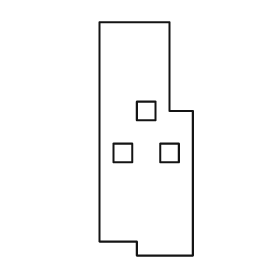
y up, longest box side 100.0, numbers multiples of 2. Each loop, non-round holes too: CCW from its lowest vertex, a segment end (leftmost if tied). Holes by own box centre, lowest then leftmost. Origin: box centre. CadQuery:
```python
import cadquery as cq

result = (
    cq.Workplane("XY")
    .moveTo(-4.0, -50.0)
    .lineTo(20.0, -50.0)
    .lineTo(20.0, 12.0)
    .lineTo(10.0, 12.0)
    .lineTo(10.0, 50.0)
    .lineTo(-20.0, 50.0)
    .lineTo(-20.0, -44.0)
    .lineTo(-4.0, -44.0)
    .close()
    .moveTo(-14.0, -10.0)
    .lineTo(-6.0, -10.0)
    .lineTo(-6.0, -2.0)
    .lineTo(-14.0, -2.0)
    .close()
    .moveTo(6.0, -10.0)
    .lineTo(14.0, -10.0)
    .lineTo(14.0, -2.0)
    .lineTo(6.0, -2.0)
    .close()
    .moveTo(-4.0, 8.0)
    .lineTo(4.0, 8.0)
    .lineTo(4.0, 16.0)
    .lineTo(-4.0, 16.0)
    .close()
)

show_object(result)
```